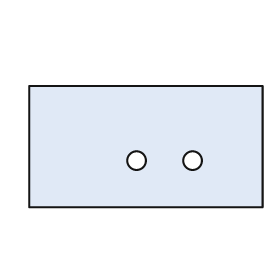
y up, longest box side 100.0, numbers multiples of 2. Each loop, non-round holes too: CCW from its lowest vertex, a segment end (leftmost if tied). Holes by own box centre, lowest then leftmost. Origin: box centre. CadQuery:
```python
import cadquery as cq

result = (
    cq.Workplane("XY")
    .moveTo(-50.0, -26.0)
    .lineTo(50.0, -26.0)
    .lineTo(50.0, 26.0)
    .lineTo(-50.0, 26.0)
    .close()
    .moveTo(-4.0, -6.0)
    .circle(4.0)
    .moveTo(20.0, -6.0)
    .circle(4.0)
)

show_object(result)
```